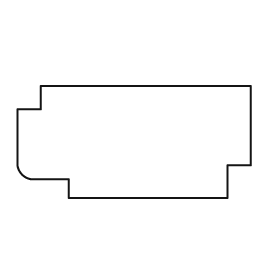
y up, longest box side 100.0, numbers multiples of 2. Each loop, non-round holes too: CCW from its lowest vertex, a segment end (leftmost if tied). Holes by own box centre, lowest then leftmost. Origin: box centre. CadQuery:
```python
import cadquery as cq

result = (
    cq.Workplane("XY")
    .moveTo(-28.0, -24.0)
    .lineTo(40.0, -24.0)
    .lineTo(40.0, -10.0)
    .lineTo(50.0, -10.0)
    .lineTo(50.0, 24.0)
    .lineTo(-40.0, 24.0)
    .lineTo(-40.0, 14.0)
    .lineTo(-50.0, 14.0)
    .lineTo(-50.0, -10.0)
    .threePointArc((-48.0, -14.0), (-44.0, -16.0))
    .lineTo(-28.0, -16.0)
    .close()
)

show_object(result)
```